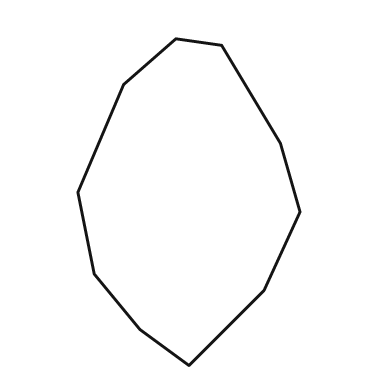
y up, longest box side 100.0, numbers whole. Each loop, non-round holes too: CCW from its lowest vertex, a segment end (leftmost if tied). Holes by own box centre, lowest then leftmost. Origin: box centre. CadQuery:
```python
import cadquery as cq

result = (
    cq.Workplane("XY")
    .moveTo(0.0, -50.0)
    .lineTo(23.0, -27.0)
    .lineTo(34.0, -3.0)
    .lineTo(28.0, 18.0)
    .lineTo(10.0, 48.0)
    .lineTo(-4.0, 50.0)
    .lineTo(-20.0, 36.0)
    .lineTo(-34.0, 3.0)
    .lineTo(-29.0, -22.0)
    .lineTo(-15.0, -39.0)
    .close()
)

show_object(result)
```